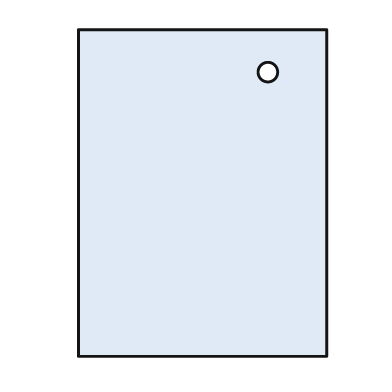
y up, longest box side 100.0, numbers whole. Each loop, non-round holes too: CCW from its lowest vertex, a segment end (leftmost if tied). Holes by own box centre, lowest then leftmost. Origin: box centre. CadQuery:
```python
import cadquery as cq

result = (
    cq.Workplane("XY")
    .moveTo(-38.0, -50.0)
    .lineTo(38.0, -50.0)
    .lineTo(38.0, 50.0)
    .lineTo(-38.0, 50.0)
    .close()
    .moveTo(20.0, 37.0)
    .circle(3.0)
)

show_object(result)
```